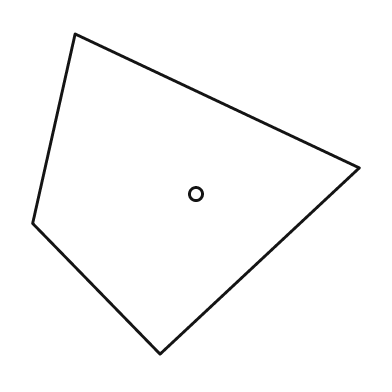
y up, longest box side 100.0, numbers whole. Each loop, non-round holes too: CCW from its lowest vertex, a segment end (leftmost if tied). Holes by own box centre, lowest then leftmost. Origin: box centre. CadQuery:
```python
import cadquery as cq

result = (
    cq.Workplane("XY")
    .moveTo(-11.0, -49.0)
    .lineTo(50.0, 8.0)
    .lineTo(-37.0, 49.0)
    .lineTo(-50.0, -9.0)
    .close()
    .moveTo(0.0, 0.0)
    .circle(2.0)
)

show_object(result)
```